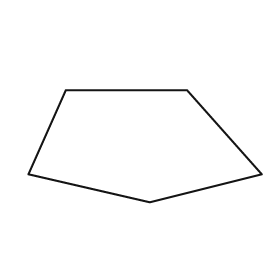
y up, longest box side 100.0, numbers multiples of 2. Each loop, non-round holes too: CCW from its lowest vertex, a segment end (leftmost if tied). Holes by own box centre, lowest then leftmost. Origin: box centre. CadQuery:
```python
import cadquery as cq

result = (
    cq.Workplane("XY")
    .moveTo(2.0, -24.0)
    .lineTo(50.0, -12.0)
    .lineTo(18.0, 24.0)
    .lineTo(-34.0, 24.0)
    .lineTo(-50.0, -12.0)
    .close()
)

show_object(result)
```